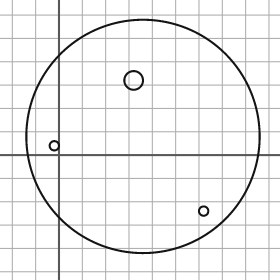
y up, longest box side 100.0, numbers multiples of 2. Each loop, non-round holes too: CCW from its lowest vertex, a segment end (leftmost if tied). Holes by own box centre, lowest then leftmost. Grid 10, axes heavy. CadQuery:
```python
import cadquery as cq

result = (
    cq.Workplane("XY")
    .moveTo(36.0, 8.0)
    .circle(50.0)
    .moveTo(62.0, -24.0)
    .circle(2.0)
    .moveTo(-2.0, 4.0)
    .circle(2.0)
    .moveTo(32.0, 32.0)
    .circle(4.0)
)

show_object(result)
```